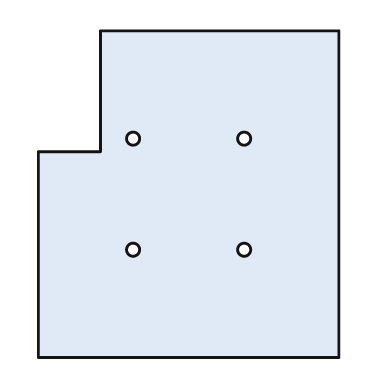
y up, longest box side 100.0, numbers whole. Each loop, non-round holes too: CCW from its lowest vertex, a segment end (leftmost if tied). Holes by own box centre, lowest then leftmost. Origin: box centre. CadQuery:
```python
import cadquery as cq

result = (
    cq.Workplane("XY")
    .moveTo(-46.0, -50.0)
    .lineTo(46.0, -50.0)
    .lineTo(46.0, 50.0)
    .lineTo(-27.0, 50.0)
    .lineTo(-27.0, 13.0)
    .lineTo(-46.0, 13.0)
    .close()
    .moveTo(-17.0, -17.0)
    .circle(2.0)
    .moveTo(17.0, -17.0)
    .circle(2.0)
    .moveTo(-17.0, 17.0)
    .circle(2.0)
    .moveTo(17.0, 17.0)
    .circle(2.0)
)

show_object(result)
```